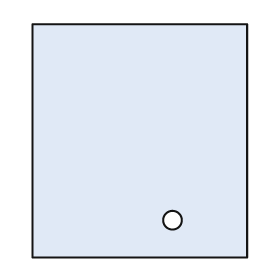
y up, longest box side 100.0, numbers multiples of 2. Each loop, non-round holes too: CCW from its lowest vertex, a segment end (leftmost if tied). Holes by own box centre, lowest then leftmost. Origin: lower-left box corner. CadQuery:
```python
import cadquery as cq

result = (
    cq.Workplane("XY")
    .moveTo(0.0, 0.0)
    .lineTo(92.0, 0.0)
    .lineTo(92.0, 100.0)
    .lineTo(0.0, 100.0)
    .close()
    .moveTo(60.0, 16.0)
    .circle(4.0)
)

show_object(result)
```